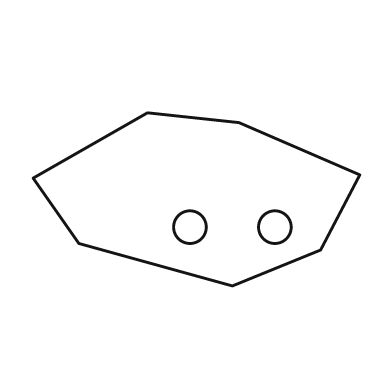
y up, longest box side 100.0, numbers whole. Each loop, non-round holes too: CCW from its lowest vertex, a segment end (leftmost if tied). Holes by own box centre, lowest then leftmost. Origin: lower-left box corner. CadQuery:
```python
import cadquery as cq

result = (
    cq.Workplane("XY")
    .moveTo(61.0, 0.0)
    .lineTo(88.0, 11.0)
    .lineTo(100.0, 34.0)
    .lineTo(63.0, 50.0)
    .lineTo(35.0, 53.0)
    .lineTo(0.0, 33.0)
    .lineTo(14.0, 13.0)
    .close()
    .moveTo(48.0, 18.0)
    .circle(5.0)
    .moveTo(74.0, 18.0)
    .circle(5.0)
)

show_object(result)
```